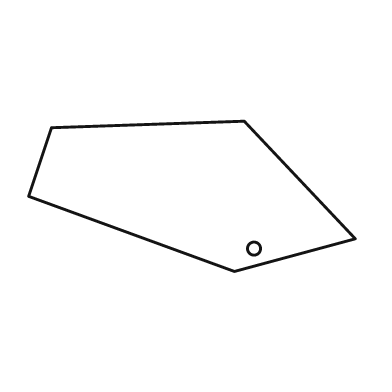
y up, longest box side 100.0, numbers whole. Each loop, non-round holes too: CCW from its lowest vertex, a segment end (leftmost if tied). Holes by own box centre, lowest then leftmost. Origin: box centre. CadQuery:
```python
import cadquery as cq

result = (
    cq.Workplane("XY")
    .moveTo(13.0, -23.0)
    .lineTo(50.0, -13.0)
    .lineTo(16.0, 23.0)
    .lineTo(-43.0, 21.0)
    .lineTo(-50.0, 0.0)
    .close()
    .moveTo(19.0, -16.0)
    .circle(2.0)
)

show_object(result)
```